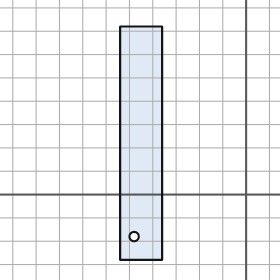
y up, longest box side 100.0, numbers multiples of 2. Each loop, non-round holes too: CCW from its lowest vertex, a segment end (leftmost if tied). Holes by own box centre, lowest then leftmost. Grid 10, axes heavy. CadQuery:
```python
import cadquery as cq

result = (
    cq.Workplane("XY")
    .moveTo(-54.0, -28.0)
    .lineTo(-36.0, -28.0)
    .lineTo(-36.0, 72.0)
    .lineTo(-54.0, 72.0)
    .close()
    .moveTo(-48.0, -18.0)
    .circle(2.0)
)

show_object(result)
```